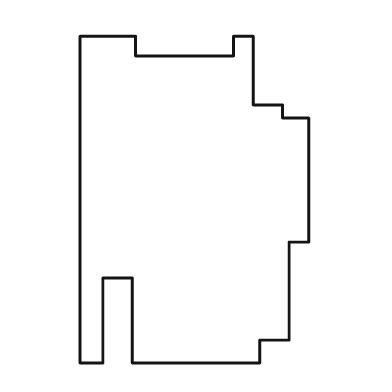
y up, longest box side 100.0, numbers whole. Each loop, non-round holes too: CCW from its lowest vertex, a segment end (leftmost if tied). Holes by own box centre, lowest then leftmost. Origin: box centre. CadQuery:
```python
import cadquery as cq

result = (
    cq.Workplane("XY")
    .moveTo(-35.0, -50.0)
    .lineTo(-28.0, -50.0)
    .lineTo(-28.0, -24.0)
    .lineTo(-19.0, -24.0)
    .lineTo(-19.0, -50.0)
    .lineTo(20.0, -50.0)
    .lineTo(20.0, -43.0)
    .lineTo(29.0, -43.0)
    .lineTo(29.0, -13.0)
    .lineTo(35.0, -13.0)
    .lineTo(35.0, 25.0)
    .lineTo(27.0, 25.0)
    .lineTo(27.0, 29.0)
    .lineTo(18.0, 29.0)
    .lineTo(18.0, 50.0)
    .lineTo(12.0, 50.0)
    .lineTo(12.0, 44.0)
    .lineTo(-18.0, 44.0)
    .lineTo(-18.0, 50.0)
    .lineTo(-35.0, 50.0)
    .close()
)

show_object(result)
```